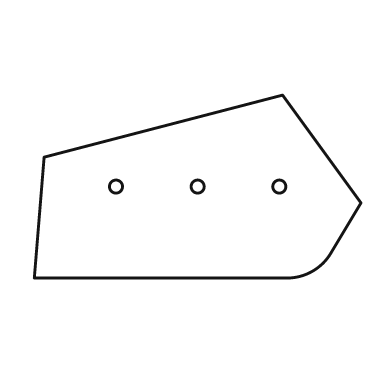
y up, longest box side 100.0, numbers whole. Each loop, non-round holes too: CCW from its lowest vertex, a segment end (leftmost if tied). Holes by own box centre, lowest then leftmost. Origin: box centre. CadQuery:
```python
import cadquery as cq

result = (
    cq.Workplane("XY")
    .moveTo(-50.0, -28.0)
    .lineTo(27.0, -28.0)
    .threePointArc((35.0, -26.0), (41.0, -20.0))
    .lineTo(50.0, -5.0)
    .lineTo(26.0, 28.0)
    .lineTo(-47.0, 9.0)
    .close()
    .moveTo(-25.0, 0.0)
    .circle(2.0)
    .moveTo(0.0, 0.0)
    .circle(2.0)
    .moveTo(25.0, 0.0)
    .circle(2.0)
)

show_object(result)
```